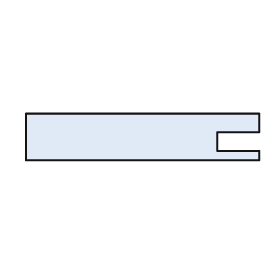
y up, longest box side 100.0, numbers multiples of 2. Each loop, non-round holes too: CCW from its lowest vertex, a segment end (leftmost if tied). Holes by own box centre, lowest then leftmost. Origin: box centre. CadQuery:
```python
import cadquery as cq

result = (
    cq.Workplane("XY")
    .moveTo(-50.0, -10.0)
    .lineTo(50.0, -10.0)
    .lineTo(50.0, -6.0)
    .lineTo(32.0, -6.0)
    .lineTo(32.0, 2.0)
    .lineTo(50.0, 2.0)
    .lineTo(50.0, 10.0)
    .lineTo(-50.0, 10.0)
    .close()
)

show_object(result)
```